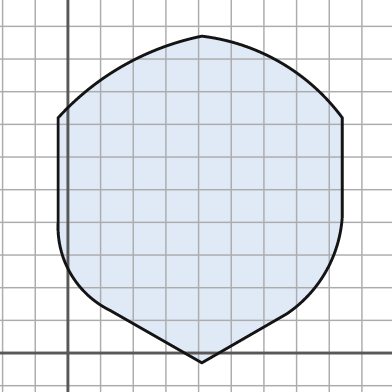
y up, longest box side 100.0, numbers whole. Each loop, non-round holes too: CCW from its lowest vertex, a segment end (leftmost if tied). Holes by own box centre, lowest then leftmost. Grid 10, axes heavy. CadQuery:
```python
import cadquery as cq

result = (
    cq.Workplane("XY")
    .moveTo(41.0, -3.0)
    .lineTo(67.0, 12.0)
    .threePointArc((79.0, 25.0), (84.0, 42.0))
    .lineTo(84.0, 72.0)
    .threePointArc((65.0, 89.0), (41.0, 97.0))
    .threePointArc((17.0, 88.0), (-3.0, 72.0))
    .lineTo(-3.0, 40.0)
    .threePointArc((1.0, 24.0), (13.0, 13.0))
    .close()
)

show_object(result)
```